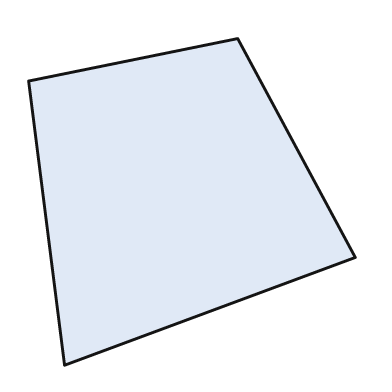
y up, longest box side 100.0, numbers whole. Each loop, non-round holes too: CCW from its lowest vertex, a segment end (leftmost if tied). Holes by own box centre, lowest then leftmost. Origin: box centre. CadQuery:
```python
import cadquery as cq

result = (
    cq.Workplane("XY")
    .moveTo(-39.0, -50.0)
    .lineTo(50.0, -17.0)
    .lineTo(14.0, 50.0)
    .lineTo(-50.0, 37.0)
    .close()
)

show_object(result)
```